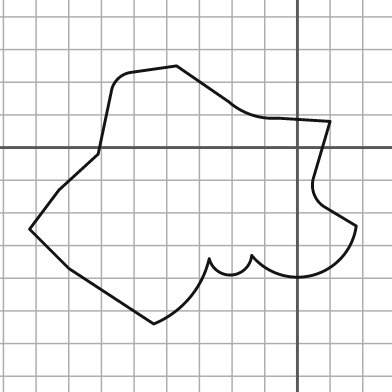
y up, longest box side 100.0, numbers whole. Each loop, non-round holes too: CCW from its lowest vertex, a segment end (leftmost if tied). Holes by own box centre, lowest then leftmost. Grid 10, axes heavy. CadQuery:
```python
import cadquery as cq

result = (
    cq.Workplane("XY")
    .moveTo(-44.0, -54.0)
    .threePointArc((-33.0, -46.0), (-27.0, -34.0))
    .threePointArc((-20.0, -39.0), (-14.0, -33.0))
    .threePointArc((5.0, -39.0), (18.0, -24.0))
    .lineTo(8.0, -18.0)
    .threePointArc((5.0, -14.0), (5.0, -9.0))
    .lineTo(10.0, 8.0)
    .lineTo(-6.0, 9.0)
    .threePointArc((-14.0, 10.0), (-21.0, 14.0))
    .lineTo(-37.0, 25.0)
    .lineTo(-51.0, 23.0)
    .threePointArc((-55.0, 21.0), (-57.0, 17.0))
    .lineTo(-61.0, -2.0)
    .lineTo(-73.0, -13.0)
    .lineTo(-82.0, -25.0)
    .lineTo(-70.0, -37.0)
    .close()
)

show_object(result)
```